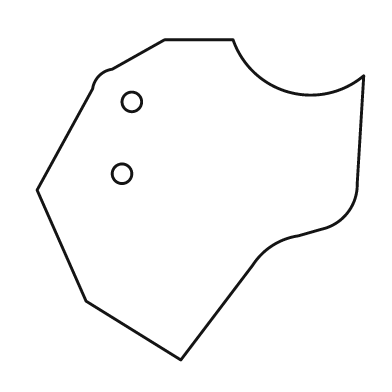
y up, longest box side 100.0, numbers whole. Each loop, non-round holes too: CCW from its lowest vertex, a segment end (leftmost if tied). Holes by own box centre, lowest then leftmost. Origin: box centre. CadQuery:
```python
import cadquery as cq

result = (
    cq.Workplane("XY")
    .moveTo(-6.0, -49.0)
    .lineTo(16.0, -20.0)
    .threePointArc((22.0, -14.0), (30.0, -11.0))
    .lineTo(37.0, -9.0)
    .threePointArc((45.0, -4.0), (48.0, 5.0))
    .lineTo(50.0, 38.0)
    .threePointArc((27.0, 33.0), (10.0, 49.0))
    .lineTo(-11.0, 49.0)
    .lineTo(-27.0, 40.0)
    .threePointArc((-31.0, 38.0), (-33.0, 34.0))
    .lineTo(-50.0, 3.0)
    .lineTo(-35.0, -31.0)
    .close()
    .moveTo(-24.0, 8.0)
    .circle(3.0)
    .moveTo(-21.0, 30.0)
    .circle(3.0)
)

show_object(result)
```